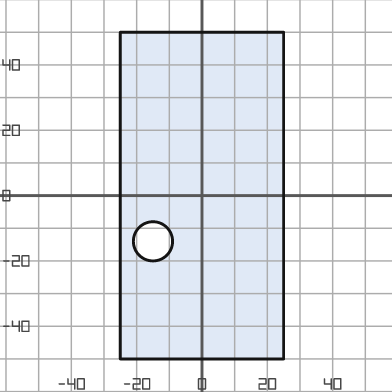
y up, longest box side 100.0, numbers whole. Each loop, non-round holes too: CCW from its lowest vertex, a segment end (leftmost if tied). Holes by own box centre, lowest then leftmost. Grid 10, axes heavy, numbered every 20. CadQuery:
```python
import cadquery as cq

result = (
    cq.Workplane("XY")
    .moveTo(-25.0, -50.0)
    .lineTo(25.0, -50.0)
    .lineTo(25.0, 50.0)
    .lineTo(-25.0, 50.0)
    .close()
    .moveTo(-15.0, -14.0)
    .circle(6.0)
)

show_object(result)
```